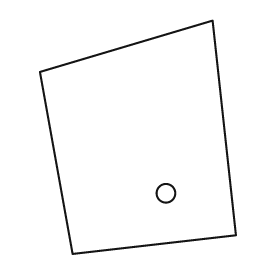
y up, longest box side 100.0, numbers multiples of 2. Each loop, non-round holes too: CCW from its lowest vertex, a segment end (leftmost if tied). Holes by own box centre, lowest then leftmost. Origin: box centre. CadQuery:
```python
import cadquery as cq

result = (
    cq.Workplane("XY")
    .moveTo(-28.0, -50.0)
    .lineTo(42.0, -42.0)
    .lineTo(32.0, 50.0)
    .lineTo(-42.0, 28.0)
    .close()
    .moveTo(12.0, -24.0)
    .circle(4.0)
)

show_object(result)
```